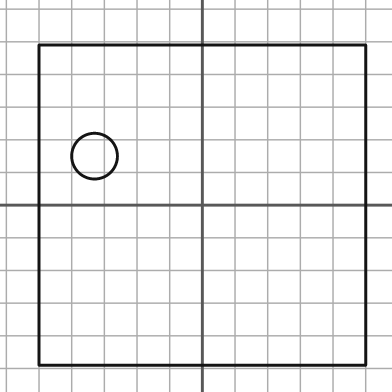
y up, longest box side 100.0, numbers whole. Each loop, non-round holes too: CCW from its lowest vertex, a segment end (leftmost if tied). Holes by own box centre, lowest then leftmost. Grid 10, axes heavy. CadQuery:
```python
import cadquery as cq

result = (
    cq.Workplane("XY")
    .moveTo(-50.0, -49.0)
    .lineTo(50.0, -49.0)
    .lineTo(50.0, 49.0)
    .lineTo(-50.0, 49.0)
    .close()
    .moveTo(-33.0, 15.0)
    .circle(7.0)
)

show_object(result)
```